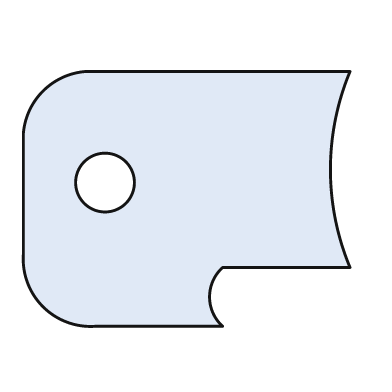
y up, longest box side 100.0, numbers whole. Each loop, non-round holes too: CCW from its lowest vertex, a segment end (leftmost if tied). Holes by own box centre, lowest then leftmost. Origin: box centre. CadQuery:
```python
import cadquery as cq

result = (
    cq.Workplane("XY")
    .moveTo(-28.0, -39.0)
    .lineTo(11.0, -39.0)
    .threePointArc((7.0, -30.0), (11.0, -21.0))
    .lineTo(50.0, -21.0)
    .threePointArc((44.0, 9.0), (50.0, 39.0))
    .lineTo(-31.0, 39.0)
    .threePointArc((-44.0, 33.0), (-50.0, 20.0))
    .lineTo(-50.0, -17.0)
    .threePointArc((-44.0, -33.0), (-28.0, -39.0))
    .close()
    .moveTo(-25.0, 5.0)
    .circle(9.0)
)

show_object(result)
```